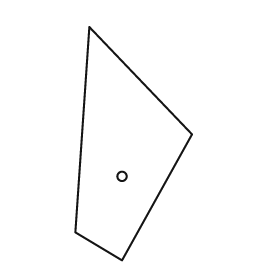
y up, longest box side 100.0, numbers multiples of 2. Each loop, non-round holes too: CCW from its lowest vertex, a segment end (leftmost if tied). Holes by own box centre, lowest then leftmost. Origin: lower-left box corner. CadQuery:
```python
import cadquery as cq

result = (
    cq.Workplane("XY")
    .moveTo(20.0, 0.0)
    .lineTo(50.0, 54.0)
    .lineTo(6.0, 100.0)
    .lineTo(0.0, 12.0)
    .close()
    .moveTo(20.0, 36.0)
    .circle(2.0)
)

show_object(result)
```